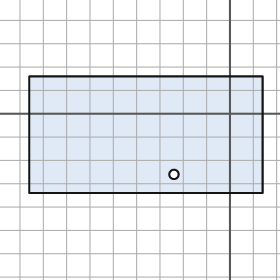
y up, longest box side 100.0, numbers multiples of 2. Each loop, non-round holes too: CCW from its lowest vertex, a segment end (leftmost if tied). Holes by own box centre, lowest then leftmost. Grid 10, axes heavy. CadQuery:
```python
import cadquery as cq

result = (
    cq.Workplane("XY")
    .moveTo(-86.0, -34.0)
    .lineTo(14.0, -34.0)
    .lineTo(14.0, 16.0)
    .lineTo(-86.0, 16.0)
    .close()
    .moveTo(-24.0, -26.0)
    .circle(2.0)
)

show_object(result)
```